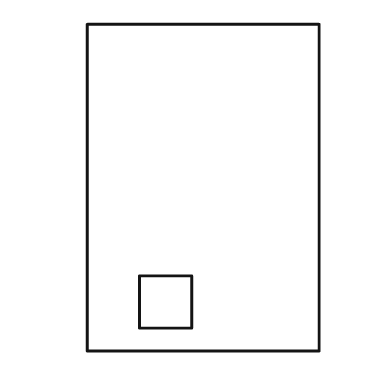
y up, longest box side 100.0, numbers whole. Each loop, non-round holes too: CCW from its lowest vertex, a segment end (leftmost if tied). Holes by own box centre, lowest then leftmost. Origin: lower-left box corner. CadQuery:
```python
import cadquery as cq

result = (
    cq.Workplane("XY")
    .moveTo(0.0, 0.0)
    .lineTo(71.0, 0.0)
    .lineTo(71.0, 100.0)
    .lineTo(0.0, 100.0)
    .close()
    .moveTo(16.0, 7.0)
    .lineTo(32.0, 7.0)
    .lineTo(32.0, 23.0)
    .lineTo(16.0, 23.0)
    .close()
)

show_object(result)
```